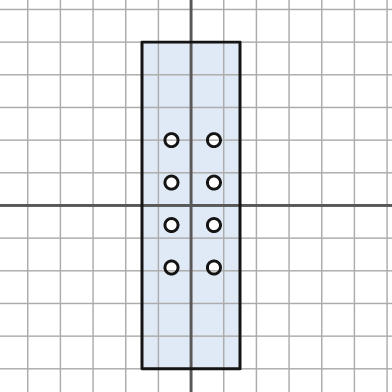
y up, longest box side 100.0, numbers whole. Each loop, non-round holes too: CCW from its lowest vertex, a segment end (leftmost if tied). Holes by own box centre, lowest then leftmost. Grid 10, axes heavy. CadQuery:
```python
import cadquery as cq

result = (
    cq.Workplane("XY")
    .moveTo(-15.0, -50.0)
    .lineTo(15.0, -50.0)
    .lineTo(15.0, 50.0)
    .lineTo(-15.0, 50.0)
    .close()
    .moveTo(-6.0, -19.0)
    .circle(2.0)
    .moveTo(7.0, -19.0)
    .circle(2.0)
    .moveTo(-6.0, -6.0)
    .circle(2.0)
    .moveTo(7.0, -6.0)
    .circle(2.0)
    .moveTo(-6.0, 7.0)
    .circle(2.0)
    .moveTo(7.0, 7.0)
    .circle(2.0)
    .moveTo(-6.0, 20.0)
    .circle(2.0)
    .moveTo(7.0, 20.0)
    .circle(2.0)
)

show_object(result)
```